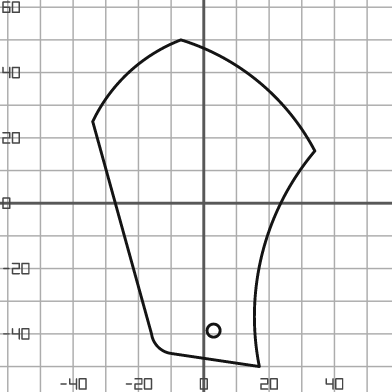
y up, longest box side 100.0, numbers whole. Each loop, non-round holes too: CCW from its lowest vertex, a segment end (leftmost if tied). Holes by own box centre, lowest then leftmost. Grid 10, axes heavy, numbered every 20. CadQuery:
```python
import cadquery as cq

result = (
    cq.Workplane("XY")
    .moveTo(17.0, -50.0)
    .threePointArc((18.0, -15.0), (34.0, 16.0))
    .threePointArc((17.0, 37.0), (-7.0, 50.0))
    .threePointArc((-23.0, 40.0), (-34.0, 25.0))
    .lineTo(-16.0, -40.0)
    .threePointArc((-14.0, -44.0), (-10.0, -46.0))
    .close()
    .moveTo(3.0, -39.0)
    .circle(2.0)
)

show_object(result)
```